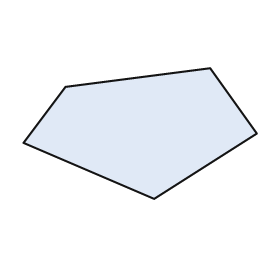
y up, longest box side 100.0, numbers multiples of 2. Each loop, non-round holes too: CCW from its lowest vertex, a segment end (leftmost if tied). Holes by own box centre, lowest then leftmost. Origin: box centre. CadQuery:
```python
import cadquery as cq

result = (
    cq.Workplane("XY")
    .moveTo(6.0, -28.0)
    .lineTo(50.0, 0.0)
    .lineTo(30.0, 28.0)
    .lineTo(-32.0, 20.0)
    .lineTo(-50.0, -4.0)
    .close()
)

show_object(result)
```